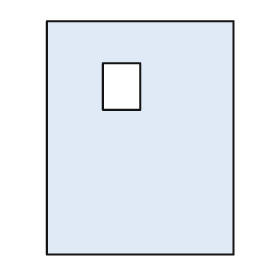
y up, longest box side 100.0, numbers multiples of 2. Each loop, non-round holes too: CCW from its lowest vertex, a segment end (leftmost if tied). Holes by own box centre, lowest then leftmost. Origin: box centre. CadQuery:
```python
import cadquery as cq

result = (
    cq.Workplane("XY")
    .moveTo(-40.0, -50.0)
    .lineTo(40.0, -50.0)
    .lineTo(40.0, 50.0)
    .lineTo(-40.0, 50.0)
    .close()
    .moveTo(-16.0, 12.0)
    .lineTo(0.0, 12.0)
    .lineTo(0.0, 32.0)
    .lineTo(-16.0, 32.0)
    .close()
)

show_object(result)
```